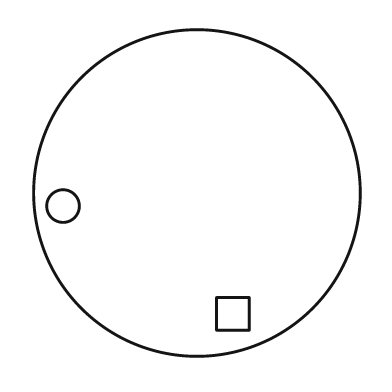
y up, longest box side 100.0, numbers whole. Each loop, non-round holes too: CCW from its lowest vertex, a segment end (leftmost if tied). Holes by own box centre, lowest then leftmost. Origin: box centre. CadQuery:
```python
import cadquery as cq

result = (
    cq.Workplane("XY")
    .moveTo(0.0, 0.0)
    .circle(50.0)
    .moveTo(6.0, -42.0)
    .lineTo(16.0, -42.0)
    .lineTo(16.0, -32.0)
    .lineTo(6.0, -32.0)
    .close()
    .moveTo(-41.0, -4.0)
    .circle(5.0)
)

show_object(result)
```